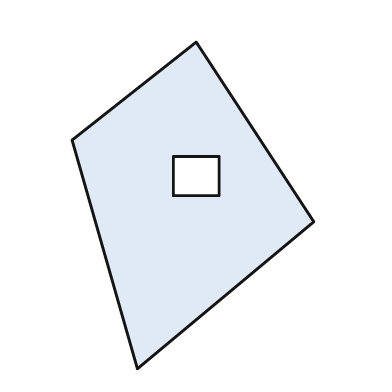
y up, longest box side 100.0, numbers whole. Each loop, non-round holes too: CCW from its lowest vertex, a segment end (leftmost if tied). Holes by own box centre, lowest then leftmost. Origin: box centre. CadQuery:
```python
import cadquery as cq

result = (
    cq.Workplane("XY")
    .moveTo(-17.0, -50.0)
    .lineTo(37.0, -5.0)
    .lineTo(1.0, 50.0)
    .lineTo(-37.0, 20.0)
    .close()
    .moveTo(-6.0, 3.0)
    .lineTo(8.0, 3.0)
    .lineTo(8.0, 15.0)
    .lineTo(-6.0, 15.0)
    .close()
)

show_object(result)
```